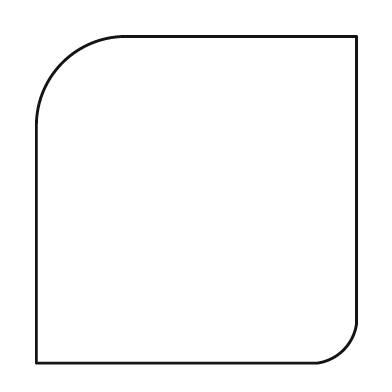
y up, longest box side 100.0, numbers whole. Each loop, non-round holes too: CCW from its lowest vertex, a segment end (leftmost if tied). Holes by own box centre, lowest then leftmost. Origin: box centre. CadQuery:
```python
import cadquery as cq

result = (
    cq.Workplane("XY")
    .moveTo(-49.0, -50.0)
    .lineTo(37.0, -50.0)
    .threePointArc((45.0, -46.0), (49.0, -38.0))
    .lineTo(49.0, 50.0)
    .lineTo(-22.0, 50.0)
    .threePointArc((-41.0, 42.0), (-49.0, 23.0))
    .close()
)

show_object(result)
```